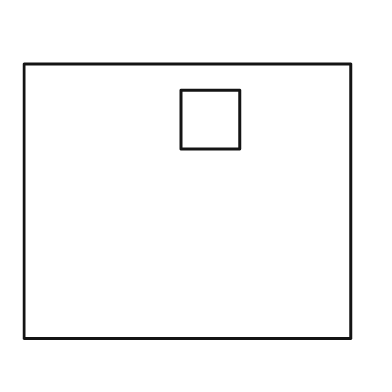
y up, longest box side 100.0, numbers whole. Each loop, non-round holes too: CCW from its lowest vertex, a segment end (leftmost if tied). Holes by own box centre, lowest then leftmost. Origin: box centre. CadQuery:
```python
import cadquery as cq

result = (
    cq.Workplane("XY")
    .moveTo(-50.0, -42.0)
    .lineTo(50.0, -42.0)
    .lineTo(50.0, 42.0)
    .lineTo(-50.0, 42.0)
    .close()
    .moveTo(-2.0, 16.0)
    .lineTo(16.0, 16.0)
    .lineTo(16.0, 34.0)
    .lineTo(-2.0, 34.0)
    .close()
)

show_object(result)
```